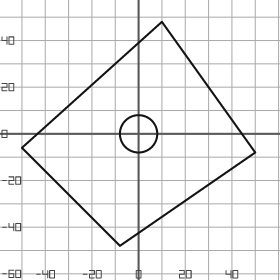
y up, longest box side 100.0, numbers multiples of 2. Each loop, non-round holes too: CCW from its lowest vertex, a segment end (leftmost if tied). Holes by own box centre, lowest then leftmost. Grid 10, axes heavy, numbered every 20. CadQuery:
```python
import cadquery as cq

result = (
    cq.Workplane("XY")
    .moveTo(-8.0, -48.0)
    .lineTo(50.0, -8.0)
    .lineTo(10.0, 48.0)
    .lineTo(-50.0, -6.0)
    .close()
    .moveTo(0.0, 0.0)
    .circle(8.0)
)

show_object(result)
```